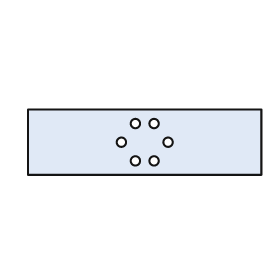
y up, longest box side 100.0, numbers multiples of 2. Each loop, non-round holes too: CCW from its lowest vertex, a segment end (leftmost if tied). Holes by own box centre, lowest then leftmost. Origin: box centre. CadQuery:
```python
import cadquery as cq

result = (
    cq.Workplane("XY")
    .moveTo(-50.0, -14.0)
    .lineTo(50.0, -14.0)
    .lineTo(50.0, 14.0)
    .lineTo(-50.0, 14.0)
    .close()
    .moveTo(-4.0, -8.0)
    .circle(2.0)
    .moveTo(4.0, -8.0)
    .circle(2.0)
    .moveTo(-10.0, 0.0)
    .circle(2.0)
    .moveTo(10.0, 0.0)
    .circle(2.0)
    .moveTo(-4.0, 8.0)
    .circle(2.0)
    .moveTo(4.0, 8.0)
    .circle(2.0)
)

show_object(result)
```